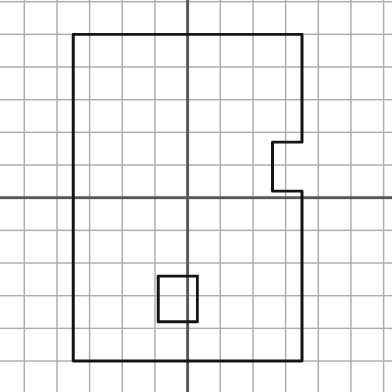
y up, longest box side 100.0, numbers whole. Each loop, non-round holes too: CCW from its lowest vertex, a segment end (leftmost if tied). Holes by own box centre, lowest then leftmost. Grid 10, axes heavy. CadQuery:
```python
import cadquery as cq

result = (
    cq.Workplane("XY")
    .moveTo(-35.0, -50.0)
    .lineTo(35.0, -50.0)
    .lineTo(35.0, 2.0)
    .lineTo(26.0, 2.0)
    .lineTo(26.0, 17.0)
    .lineTo(35.0, 17.0)
    .lineTo(35.0, 50.0)
    .lineTo(-35.0, 50.0)
    .close()
    .moveTo(-9.0, -38.0)
    .lineTo(3.0, -38.0)
    .lineTo(3.0, -24.0)
    .lineTo(-9.0, -24.0)
    .close()
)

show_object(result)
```